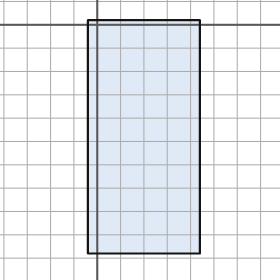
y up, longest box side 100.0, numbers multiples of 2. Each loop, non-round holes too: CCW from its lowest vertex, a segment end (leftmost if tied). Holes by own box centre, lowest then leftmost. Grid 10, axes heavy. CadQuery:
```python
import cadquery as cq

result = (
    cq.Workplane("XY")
    .moveTo(-4.0, -98.0)
    .lineTo(44.0, -98.0)
    .lineTo(44.0, 2.0)
    .lineTo(-4.0, 2.0)
    .close()
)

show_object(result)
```